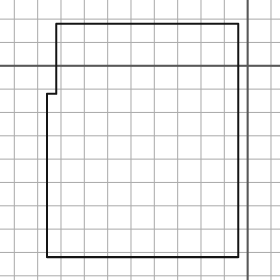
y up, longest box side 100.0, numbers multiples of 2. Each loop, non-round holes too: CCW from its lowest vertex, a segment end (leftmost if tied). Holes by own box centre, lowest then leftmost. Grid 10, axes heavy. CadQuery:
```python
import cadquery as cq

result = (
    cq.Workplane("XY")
    .moveTo(-86.0, -82.0)
    .lineTo(-4.0, -82.0)
    .lineTo(-4.0, 18.0)
    .lineTo(-82.0, 18.0)
    .lineTo(-82.0, -12.0)
    .lineTo(-86.0, -12.0)
    .close()
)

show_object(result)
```